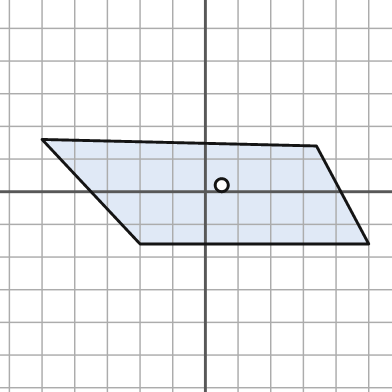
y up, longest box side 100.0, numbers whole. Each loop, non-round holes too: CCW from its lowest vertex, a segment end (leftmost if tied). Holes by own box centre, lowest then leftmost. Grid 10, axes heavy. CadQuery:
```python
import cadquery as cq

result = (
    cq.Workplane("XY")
    .moveTo(-20.0, -16.0)
    .lineTo(50.0, -16.0)
    .lineTo(34.0, 14.0)
    .lineTo(-50.0, 16.0)
    .close()
    .moveTo(5.0, 2.0)
    .circle(2.0)
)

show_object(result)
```